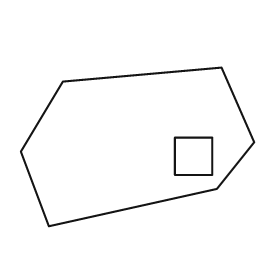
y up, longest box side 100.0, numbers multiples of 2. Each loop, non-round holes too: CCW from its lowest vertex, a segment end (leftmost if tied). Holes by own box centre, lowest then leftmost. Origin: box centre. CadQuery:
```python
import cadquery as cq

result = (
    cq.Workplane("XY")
    .moveTo(-38.0, -34.0)
    .lineTo(34.0, -18.0)
    .lineTo(50.0, 2.0)
    .lineTo(36.0, 34.0)
    .lineTo(-32.0, 28.0)
    .lineTo(-50.0, -2.0)
    .close()
    .moveTo(16.0, -12.0)
    .lineTo(32.0, -12.0)
    .lineTo(32.0, 4.0)
    .lineTo(16.0, 4.0)
    .close()
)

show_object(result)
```